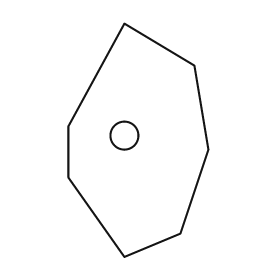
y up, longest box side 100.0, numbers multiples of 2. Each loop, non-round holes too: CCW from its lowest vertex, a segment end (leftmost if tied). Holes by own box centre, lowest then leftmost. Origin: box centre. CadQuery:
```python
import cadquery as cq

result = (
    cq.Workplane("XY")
    .moveTo(-6.0, -50.0)
    .lineTo(18.0, -40.0)
    .lineTo(30.0, -4.0)
    .lineTo(24.0, 32.0)
    .lineTo(-6.0, 50.0)
    .lineTo(-30.0, 6.0)
    .lineTo(-30.0, -16.0)
    .close()
    .moveTo(-6.0, 2.0)
    .circle(6.0)
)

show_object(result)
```